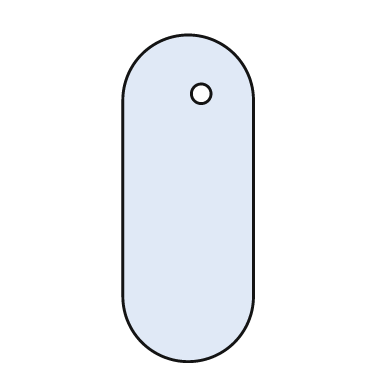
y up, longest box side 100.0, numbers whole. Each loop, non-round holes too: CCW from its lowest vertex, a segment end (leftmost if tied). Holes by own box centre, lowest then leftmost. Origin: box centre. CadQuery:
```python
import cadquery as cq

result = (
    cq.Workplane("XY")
    .moveTo(-20.0, -30.0)
    .threePointArc((0.0, -50.0), (20.0, -30.0))
    .lineTo(20.0, 30.0)
    .threePointArc((0.0, 50.0), (-20.0, 30.0))
    .close()
    .moveTo(4.0, 32.0)
    .circle(3.0)
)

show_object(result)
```